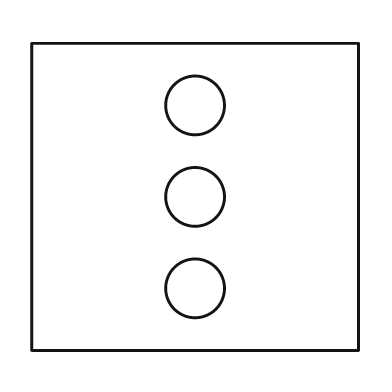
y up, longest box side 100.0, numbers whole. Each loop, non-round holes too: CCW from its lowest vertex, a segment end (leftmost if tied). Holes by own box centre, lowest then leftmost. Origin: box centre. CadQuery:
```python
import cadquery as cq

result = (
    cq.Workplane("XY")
    .moveTo(-50.0, -47.0)
    .lineTo(50.0, -47.0)
    .lineTo(50.0, 47.0)
    .lineTo(-50.0, 47.0)
    .close()
    .moveTo(0.0, -28.0)
    .circle(9.0)
    .moveTo(0.0, 0.0)
    .circle(9.0)
    .moveTo(0.0, 28.0)
    .circle(9.0)
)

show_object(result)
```